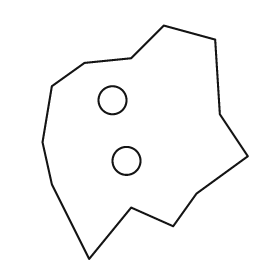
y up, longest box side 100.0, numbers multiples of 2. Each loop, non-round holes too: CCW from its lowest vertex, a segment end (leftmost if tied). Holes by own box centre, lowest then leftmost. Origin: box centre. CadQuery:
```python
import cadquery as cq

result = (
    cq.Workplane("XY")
    .moveTo(-24.0, -50.0)
    .lineTo(-6.0, -28.0)
    .lineTo(12.0, -36.0)
    .lineTo(22.0, -22.0)
    .lineTo(44.0, -6.0)
    .lineTo(32.0, 12.0)
    .lineTo(30.0, 44.0)
    .lineTo(8.0, 50.0)
    .lineTo(-6.0, 36.0)
    .lineTo(-26.0, 34.0)
    .lineTo(-40.0, 24.0)
    .lineTo(-44.0, 0.0)
    .lineTo(-40.0, -18.0)
    .close()
    .moveTo(-8.0, -8.0)
    .circle(6.0)
    .moveTo(-14.0, 18.0)
    .circle(6.0)
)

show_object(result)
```